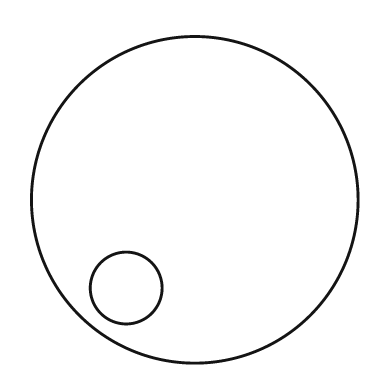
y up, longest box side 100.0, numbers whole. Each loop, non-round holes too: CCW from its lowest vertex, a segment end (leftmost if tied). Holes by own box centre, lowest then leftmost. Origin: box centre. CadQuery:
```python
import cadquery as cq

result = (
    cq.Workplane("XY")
    .moveTo(0.0, 0.0)
    .circle(50.0)
    .moveTo(-21.0, -27.0)
    .circle(11.0)
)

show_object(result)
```